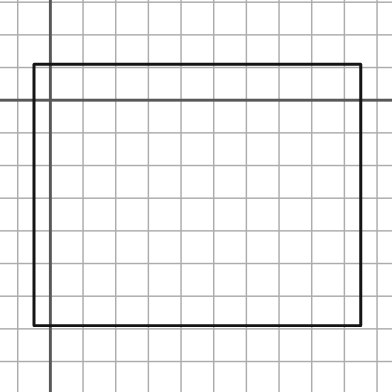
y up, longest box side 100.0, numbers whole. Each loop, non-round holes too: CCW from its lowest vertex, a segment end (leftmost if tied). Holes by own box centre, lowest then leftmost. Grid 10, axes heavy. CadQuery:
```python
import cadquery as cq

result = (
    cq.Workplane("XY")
    .moveTo(-5.0, -69.0)
    .lineTo(95.0, -69.0)
    .lineTo(95.0, 11.0)
    .lineTo(-5.0, 11.0)
    .close()
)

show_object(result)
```